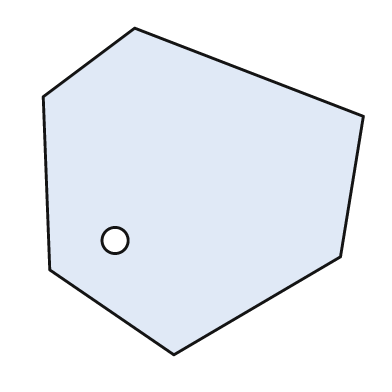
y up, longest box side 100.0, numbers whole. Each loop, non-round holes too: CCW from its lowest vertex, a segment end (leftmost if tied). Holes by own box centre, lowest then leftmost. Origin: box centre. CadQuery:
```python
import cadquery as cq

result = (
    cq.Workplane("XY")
    .moveTo(-9.0, -50.0)
    .lineTo(42.0, -20.0)
    .lineTo(49.0, 23.0)
    .lineTo(-21.0, 50.0)
    .lineTo(-49.0, 29.0)
    .lineTo(-47.0, -24.0)
    .close()
    .moveTo(-27.0, -15.0)
    .circle(4.0)
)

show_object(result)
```